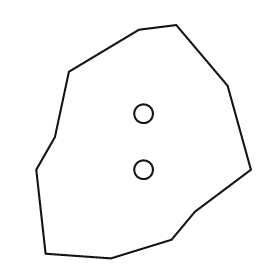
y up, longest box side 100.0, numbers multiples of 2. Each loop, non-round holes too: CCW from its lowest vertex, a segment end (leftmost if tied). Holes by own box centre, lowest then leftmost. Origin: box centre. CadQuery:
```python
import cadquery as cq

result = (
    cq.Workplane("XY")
    .moveTo(-14.0, -50.0)
    .lineTo(12.0, -42.0)
    .lineTo(22.0, -30.0)
    .lineTo(46.0, -12.0)
    .lineTo(36.0, 24.0)
    .lineTo(14.0, 50.0)
    .lineTo(-2.0, 48.0)
    .lineTo(-32.0, 30.0)
    .lineTo(-38.0, 2.0)
    .lineTo(-46.0, -12.0)
    .lineTo(-42.0, -48.0)
    .close()
    .moveTo(0.0, -12.0)
    .circle(4.0)
    .moveTo(0.0, 12.0)
    .circle(4.0)
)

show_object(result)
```